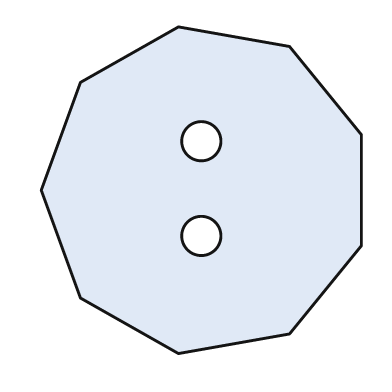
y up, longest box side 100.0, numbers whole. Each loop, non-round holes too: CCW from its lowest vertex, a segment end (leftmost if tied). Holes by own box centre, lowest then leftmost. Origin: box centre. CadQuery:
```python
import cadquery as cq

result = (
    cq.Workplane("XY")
    .moveTo(-7.0, -50.0)
    .lineTo(27.0, -44.0)
    .lineTo(49.0, -17.0)
    .lineTo(49.0, 17.0)
    .lineTo(27.0, 44.0)
    .lineTo(-7.0, 50.0)
    .lineTo(-37.0, 33.0)
    .lineTo(-49.0, 0.0)
    .lineTo(-37.0, -33.0)
    .close()
    .moveTo(0.0, -14.0)
    .circle(6.0)
    .moveTo(0.0, 15.0)
    .circle(6.0)
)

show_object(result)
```